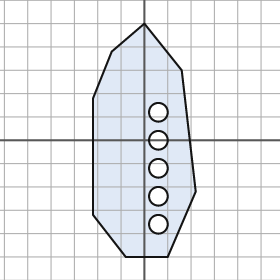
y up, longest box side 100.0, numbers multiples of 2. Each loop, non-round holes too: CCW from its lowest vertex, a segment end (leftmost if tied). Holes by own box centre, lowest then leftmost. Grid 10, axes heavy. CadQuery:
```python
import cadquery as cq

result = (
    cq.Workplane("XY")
    .moveTo(-8.0, -50.0)
    .lineTo(10.0, -50.0)
    .lineTo(22.0, -22.0)
    .lineTo(16.0, 30.0)
    .lineTo(0.0, 50.0)
    .lineTo(-14.0, 38.0)
    .lineTo(-22.0, 18.0)
    .lineTo(-22.0, -32.0)
    .close()
    .moveTo(6.0, -36.0)
    .circle(4.0)
    .moveTo(6.0, -24.0)
    .circle(4.0)
    .moveTo(6.0, -12.0)
    .circle(4.0)
    .moveTo(6.0, 0.0)
    .circle(4.0)
    .moveTo(6.0, 12.0)
    .circle(4.0)
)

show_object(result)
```